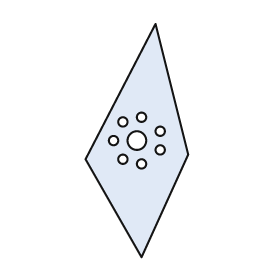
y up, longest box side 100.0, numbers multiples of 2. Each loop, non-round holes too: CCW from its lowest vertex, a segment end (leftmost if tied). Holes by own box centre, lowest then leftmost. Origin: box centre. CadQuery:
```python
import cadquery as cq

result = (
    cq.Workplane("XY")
    .moveTo(2.0, -50.0)
    .lineTo(22.0, -6.0)
    .lineTo(8.0, 50.0)
    .lineTo(-22.0, -8.0)
    .close()
    .moveTo(2.0, -10.0)
    .circle(2.0)
    .moveTo(-6.0, -8.0)
    .circle(2.0)
    .moveTo(10.0, -4.0)
    .circle(2.0)
    .moveTo(-10.0, 0.0)
    .circle(2.0)
    .moveTo(0.0, 0.0)
    .circle(4.0)
    .moveTo(10.0, 4.0)
    .circle(2.0)
    .moveTo(-6.0, 8.0)
    .circle(2.0)
    .moveTo(2.0, 10.0)
    .circle(2.0)
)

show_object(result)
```